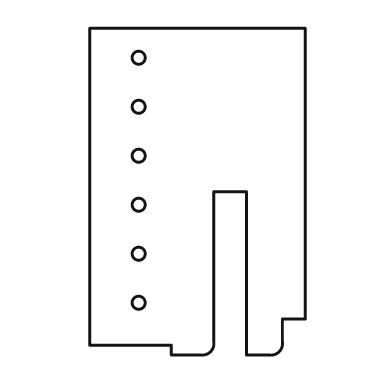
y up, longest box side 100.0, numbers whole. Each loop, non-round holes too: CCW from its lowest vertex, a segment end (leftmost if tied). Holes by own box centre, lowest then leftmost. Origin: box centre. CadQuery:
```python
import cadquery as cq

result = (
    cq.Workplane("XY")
    .moveTo(-8.0, -50.0)
    .lineTo(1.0, -50.0)
    .threePointArc((4.0, -49.0), (5.0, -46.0))
    .lineTo(5.0, 0.0)
    .lineTo(15.0, 0.0)
    .lineTo(15.0, -50.0)
    .lineTo(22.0, -50.0)
    .threePointArc((25.0, -49.0), (26.0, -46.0))
    .lineTo(26.0, -39.0)
    .lineTo(33.0, -39.0)
    .lineTo(33.0, 50.0)
    .lineTo(-33.0, 50.0)
    .lineTo(-33.0, -47.0)
    .lineTo(-8.0, -47.0)
    .close()
    .moveTo(-18.0, -34.0)
    .circle(2.0)
    .moveTo(-18.0, -19.0)
    .circle(2.0)
    .moveTo(-18.0, -4.0)
    .circle(2.0)
    .moveTo(-18.0, 11.0)
    .circle(2.0)
    .moveTo(-18.0, 26.0)
    .circle(2.0)
    .moveTo(-18.0, 41.0)
    .circle(2.0)
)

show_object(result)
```